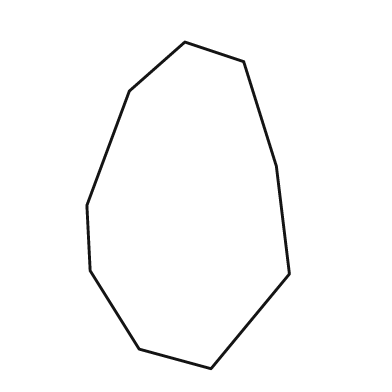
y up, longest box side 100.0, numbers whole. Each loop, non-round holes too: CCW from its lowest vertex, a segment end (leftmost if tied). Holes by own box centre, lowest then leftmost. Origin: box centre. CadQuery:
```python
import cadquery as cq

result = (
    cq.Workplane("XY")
    .moveTo(7.0, -50.0)
    .lineTo(31.0, -21.0)
    .lineTo(27.0, 12.0)
    .lineTo(17.0, 44.0)
    .lineTo(-1.0, 50.0)
    .lineTo(-18.0, 35.0)
    .lineTo(-31.0, 0.0)
    .lineTo(-30.0, -20.0)
    .lineTo(-15.0, -44.0)
    .close()
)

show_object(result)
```